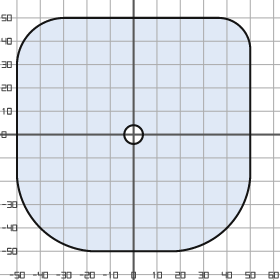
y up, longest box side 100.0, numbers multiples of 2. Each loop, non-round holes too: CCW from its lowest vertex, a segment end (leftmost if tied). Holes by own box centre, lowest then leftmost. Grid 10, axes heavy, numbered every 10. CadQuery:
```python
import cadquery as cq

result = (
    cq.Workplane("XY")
    .moveTo(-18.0, -50.0)
    .lineTo(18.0, -50.0)
    .threePointArc((40.0, -40.0), (50.0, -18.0))
    .lineTo(50.0, 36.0)
    .threePointArc((46.0, 46.0), (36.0, 50.0))
    .lineTo(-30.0, 50.0)
    .threePointArc((-44.0, 44.0), (-50.0, 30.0))
    .lineTo(-50.0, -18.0)
    .threePointArc((-40.0, -40.0), (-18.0, -50.0))
    .close()
    .moveTo(0.0, 0.0)
    .circle(4.0)
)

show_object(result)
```